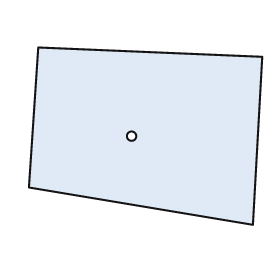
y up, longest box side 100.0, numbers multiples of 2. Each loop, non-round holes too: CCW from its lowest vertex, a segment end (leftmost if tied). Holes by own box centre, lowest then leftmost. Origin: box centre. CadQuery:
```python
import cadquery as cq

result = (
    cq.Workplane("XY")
    .moveTo(46.0, -38.0)
    .lineTo(50.0, 34.0)
    .lineTo(-46.0, 38.0)
    .lineTo(-50.0, -22.0)
    .close()
    .moveTo(-6.0, 0.0)
    .circle(2.0)
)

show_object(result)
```